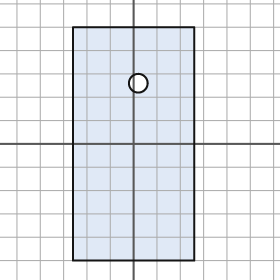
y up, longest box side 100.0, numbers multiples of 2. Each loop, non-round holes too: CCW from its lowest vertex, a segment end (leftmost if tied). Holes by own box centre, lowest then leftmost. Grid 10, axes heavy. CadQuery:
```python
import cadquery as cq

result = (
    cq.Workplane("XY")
    .moveTo(-26.0, -50.0)
    .lineTo(26.0, -50.0)
    .lineTo(26.0, 50.0)
    .lineTo(-26.0, 50.0)
    .close()
    .moveTo(2.0, 26.0)
    .circle(4.0)
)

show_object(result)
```